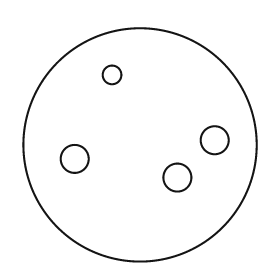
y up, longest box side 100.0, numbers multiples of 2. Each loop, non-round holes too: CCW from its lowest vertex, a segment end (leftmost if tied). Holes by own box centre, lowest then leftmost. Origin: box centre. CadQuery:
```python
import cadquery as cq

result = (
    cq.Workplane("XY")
    .moveTo(0.0, 0.0)
    .circle(50.0)
    .moveTo(16.0, -14.0)
    .circle(6.0)
    .moveTo(-28.0, -6.0)
    .circle(6.0)
    .moveTo(32.0, 2.0)
    .circle(6.0)
    .moveTo(-12.0, 30.0)
    .circle(4.0)
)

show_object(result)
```